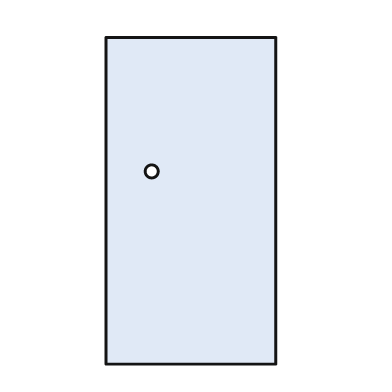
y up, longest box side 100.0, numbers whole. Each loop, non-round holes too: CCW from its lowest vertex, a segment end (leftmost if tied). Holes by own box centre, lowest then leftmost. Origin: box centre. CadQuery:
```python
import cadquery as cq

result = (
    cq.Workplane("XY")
    .moveTo(-26.0, -50.0)
    .lineTo(26.0, -50.0)
    .lineTo(26.0, 50.0)
    .lineTo(-26.0, 50.0)
    .close()
    .moveTo(-12.0, 9.0)
    .circle(2.0)
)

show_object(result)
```